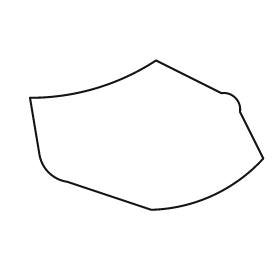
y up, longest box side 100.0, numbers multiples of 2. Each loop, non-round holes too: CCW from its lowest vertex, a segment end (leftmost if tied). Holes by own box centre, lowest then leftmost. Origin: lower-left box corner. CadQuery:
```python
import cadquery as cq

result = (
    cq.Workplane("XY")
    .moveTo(52.0, 0.0)
    .threePointArc((78.0, 6.0), (100.0, 22.0))
    .lineTo(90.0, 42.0)
    .threePointArc((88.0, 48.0), (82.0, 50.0))
    .lineTo(54.0, 64.0)
    .threePointArc((28.0, 52.0), (0.0, 48.0))
    .lineTo(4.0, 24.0)
    .threePointArc((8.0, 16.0), (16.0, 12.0))
    .close()
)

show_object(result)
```